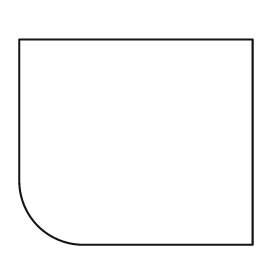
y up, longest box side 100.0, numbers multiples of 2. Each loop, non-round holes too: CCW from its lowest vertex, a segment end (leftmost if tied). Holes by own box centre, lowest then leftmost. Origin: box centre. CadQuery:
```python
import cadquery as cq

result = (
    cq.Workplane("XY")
    .moveTo(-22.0, -44.0)
    .lineTo(50.0, -44.0)
    .lineTo(50.0, 44.0)
    .lineTo(-50.0, 44.0)
    .lineTo(-50.0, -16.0)
    .threePointArc((-42.0, -36.0), (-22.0, -44.0))
    .close()
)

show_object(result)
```